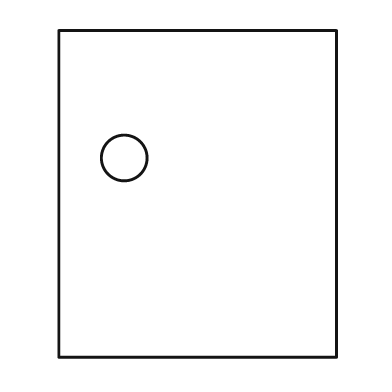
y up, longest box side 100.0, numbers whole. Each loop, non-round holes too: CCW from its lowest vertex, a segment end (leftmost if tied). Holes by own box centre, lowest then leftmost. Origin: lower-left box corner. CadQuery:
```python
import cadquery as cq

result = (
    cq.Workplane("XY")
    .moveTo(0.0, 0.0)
    .lineTo(85.0, 0.0)
    .lineTo(85.0, 100.0)
    .lineTo(0.0, 100.0)
    .close()
    .moveTo(20.0, 61.0)
    .circle(7.0)
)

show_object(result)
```